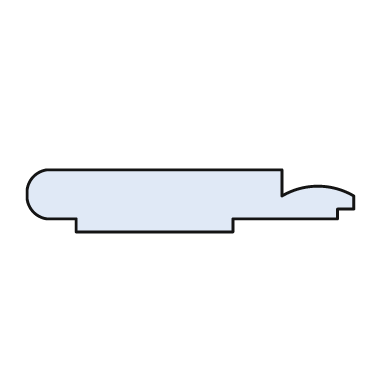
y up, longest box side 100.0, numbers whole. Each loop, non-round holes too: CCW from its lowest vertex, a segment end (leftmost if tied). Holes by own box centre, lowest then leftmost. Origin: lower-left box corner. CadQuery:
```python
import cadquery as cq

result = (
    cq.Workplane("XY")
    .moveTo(15.0, 0.0)
    .lineTo(63.0, 0.0)
    .lineTo(63.0, 4.0)
    .lineTo(95.0, 4.0)
    .lineTo(95.0, 7.0)
    .lineTo(100.0, 7.0)
    .lineTo(100.0, 11.0)
    .threePointArc((89.0, 14.0), (78.0, 11.0))
    .lineTo(78.0, 19.0)
    .lineTo(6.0, 19.0)
    .threePointArc((2.0, 17.0), (0.0, 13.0))
    .lineTo(0.0, 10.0)
    .threePointArc((2.0, 6.0), (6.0, 4.0))
    .lineTo(15.0, 4.0)
    .close()
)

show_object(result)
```